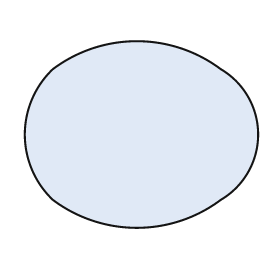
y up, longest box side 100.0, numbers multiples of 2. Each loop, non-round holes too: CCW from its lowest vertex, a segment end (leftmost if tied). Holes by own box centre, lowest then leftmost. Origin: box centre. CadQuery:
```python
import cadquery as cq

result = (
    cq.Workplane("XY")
    .moveTo(-38.0, -28.0)
    .threePointArc((-2.0, -40.0), (34.0, -28.0))
    .threePointArc((50.0, 0.0), (34.0, 28.0))
    .threePointArc((-2.0, 40.0), (-38.0, 28.0))
    .threePointArc((-50.0, 0.0), (-38.0, -28.0))
    .close()
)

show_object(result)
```